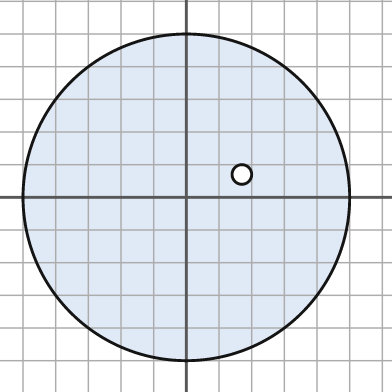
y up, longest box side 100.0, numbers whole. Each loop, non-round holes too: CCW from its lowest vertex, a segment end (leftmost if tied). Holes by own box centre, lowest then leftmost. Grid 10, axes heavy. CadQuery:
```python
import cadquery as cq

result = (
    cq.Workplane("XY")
    .moveTo(0.0, 0.0)
    .circle(50.0)
    .moveTo(17.0, 7.0)
    .circle(3.0)
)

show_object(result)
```